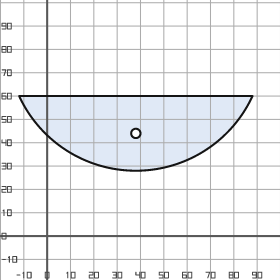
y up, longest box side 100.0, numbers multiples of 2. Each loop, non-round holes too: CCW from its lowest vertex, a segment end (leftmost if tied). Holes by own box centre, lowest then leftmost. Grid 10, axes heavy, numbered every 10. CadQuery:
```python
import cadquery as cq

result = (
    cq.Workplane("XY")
    .moveTo(-12.0, 60.0)
    .threePointArc((38.0, 28.0), (88.0, 60.0))
    .close()
    .moveTo(38.0, 44.0)
    .circle(2.0)
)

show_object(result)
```